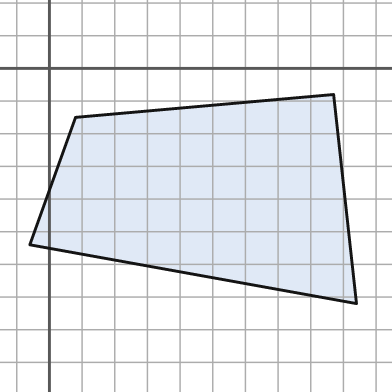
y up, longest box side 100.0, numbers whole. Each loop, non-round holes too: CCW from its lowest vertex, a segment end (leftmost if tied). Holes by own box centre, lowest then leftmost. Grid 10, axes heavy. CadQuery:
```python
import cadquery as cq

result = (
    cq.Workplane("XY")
    .moveTo(94.0, -72.0)
    .lineTo(87.0, -8.0)
    .lineTo(8.0, -15.0)
    .lineTo(-6.0, -54.0)
    .close()
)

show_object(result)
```